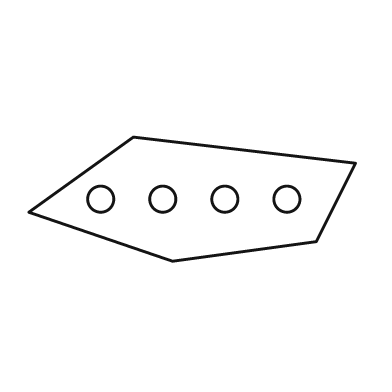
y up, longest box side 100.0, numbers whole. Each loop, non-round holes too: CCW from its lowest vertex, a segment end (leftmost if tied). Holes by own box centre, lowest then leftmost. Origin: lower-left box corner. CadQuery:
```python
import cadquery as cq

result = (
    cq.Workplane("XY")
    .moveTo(44.0, 0.0)
    .lineTo(88.0, 6.0)
    .lineTo(100.0, 30.0)
    .lineTo(32.0, 38.0)
    .lineTo(0.0, 15.0)
    .close()
    .moveTo(22.0, 19.0)
    .circle(4.0)
    .moveTo(41.0, 19.0)
    .circle(4.0)
    .moveTo(60.0, 19.0)
    .circle(4.0)
    .moveTo(79.0, 19.0)
    .circle(4.0)
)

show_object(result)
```